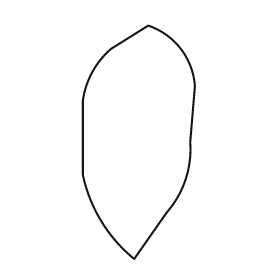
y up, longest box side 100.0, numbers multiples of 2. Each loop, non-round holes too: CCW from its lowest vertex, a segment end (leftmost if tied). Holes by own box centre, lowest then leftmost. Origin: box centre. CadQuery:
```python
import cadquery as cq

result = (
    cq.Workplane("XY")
    .moveTo(-2.0, -50.0)
    .lineTo(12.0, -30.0)
    .threePointArc((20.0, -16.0), (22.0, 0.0))
    .lineTo(24.0, 24.0)
    .threePointArc((18.0, 40.0), (4.0, 50.0))
    .lineTo(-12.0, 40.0)
    .threePointArc((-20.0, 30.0), (-24.0, 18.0))
    .lineTo(-24.0, -14.0)
    .threePointArc((-16.0, -34.0), (-2.0, -50.0))
    .close()
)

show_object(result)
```